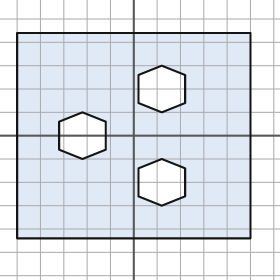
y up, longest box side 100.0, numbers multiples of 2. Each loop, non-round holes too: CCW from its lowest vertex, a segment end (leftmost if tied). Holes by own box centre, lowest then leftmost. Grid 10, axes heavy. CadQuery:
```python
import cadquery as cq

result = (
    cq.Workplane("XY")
    .moveTo(-50.0, -44.0)
    .lineTo(50.0, -44.0)
    .lineTo(50.0, 44.0)
    .lineTo(-50.0, 44.0)
    .close()
    .moveTo(12.0, -30.0)
    .lineTo(22.0, -26.0)
    .lineTo(22.0, -14.0)
    .lineTo(12.0, -10.0)
    .lineTo(2.0, -14.0)
    .lineTo(2.0, -26.0)
    .close()
    .moveTo(-22.0, -10.0)
    .lineTo(-12.0, -6.0)
    .lineTo(-12.0, 6.0)
    .lineTo(-22.0, 10.0)
    .lineTo(-32.0, 6.0)
    .lineTo(-32.0, -6.0)
    .close()
    .moveTo(12.0, 10.0)
    .lineTo(22.0, 14.0)
    .lineTo(22.0, 26.0)
    .lineTo(12.0, 30.0)
    .lineTo(2.0, 26.0)
    .lineTo(2.0, 14.0)
    .close()
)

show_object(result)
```